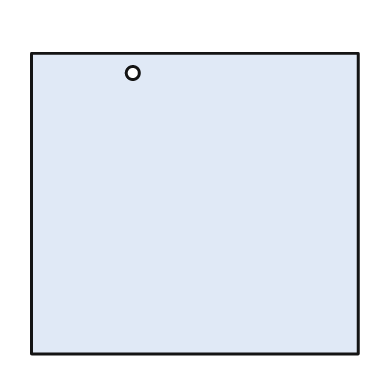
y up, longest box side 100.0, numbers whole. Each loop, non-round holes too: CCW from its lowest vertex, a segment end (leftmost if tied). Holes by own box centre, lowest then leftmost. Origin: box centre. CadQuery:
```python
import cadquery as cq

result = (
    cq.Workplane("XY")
    .moveTo(-50.0, -46.0)
    .lineTo(50.0, -46.0)
    .lineTo(50.0, 46.0)
    .lineTo(-50.0, 46.0)
    .close()
    .moveTo(-19.0, 40.0)
    .circle(2.0)
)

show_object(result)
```